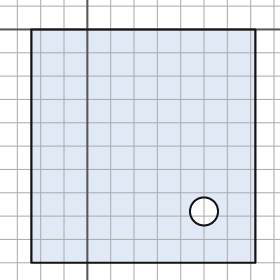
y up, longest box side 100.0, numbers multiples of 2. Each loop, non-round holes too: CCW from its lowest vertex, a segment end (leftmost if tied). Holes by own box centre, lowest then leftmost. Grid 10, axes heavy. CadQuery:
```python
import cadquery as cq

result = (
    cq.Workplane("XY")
    .moveTo(-24.0, -100.0)
    .lineTo(72.0, -100.0)
    .lineTo(72.0, 0.0)
    .lineTo(-24.0, 0.0)
    .close()
    .moveTo(50.0, -78.0)
    .circle(6.0)
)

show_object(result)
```